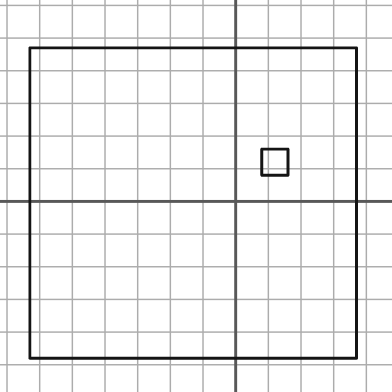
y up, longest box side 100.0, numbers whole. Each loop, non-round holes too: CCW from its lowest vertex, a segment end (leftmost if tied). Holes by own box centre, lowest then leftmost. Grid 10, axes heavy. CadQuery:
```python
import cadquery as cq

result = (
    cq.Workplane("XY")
    .moveTo(-63.0, -48.0)
    .lineTo(37.0, -48.0)
    .lineTo(37.0, 47.0)
    .lineTo(-63.0, 47.0)
    .close()
    .moveTo(8.0, 8.0)
    .lineTo(16.0, 8.0)
    .lineTo(16.0, 16.0)
    .lineTo(8.0, 16.0)
    .close()
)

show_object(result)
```